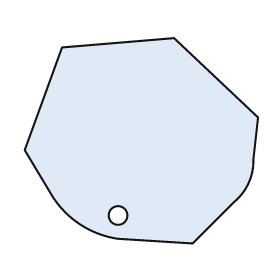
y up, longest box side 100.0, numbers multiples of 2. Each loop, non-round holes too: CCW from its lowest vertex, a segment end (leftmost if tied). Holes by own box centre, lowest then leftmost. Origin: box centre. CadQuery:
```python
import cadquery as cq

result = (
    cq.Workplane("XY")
    .moveTo(22.0, -44.0)
    .lineTo(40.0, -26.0)
    .threePointArc((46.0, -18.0), (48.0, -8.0))
    .lineTo(50.0, 10.0)
    .lineTo(14.0, 44.0)
    .lineTo(-34.0, 40.0)
    .lineTo(-50.0, -4.0)
    .lineTo(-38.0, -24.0)
    .threePointArc((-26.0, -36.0), (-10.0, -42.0))
    .close()
    .moveTo(-10.0, -32.0)
    .circle(4.0)
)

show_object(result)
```